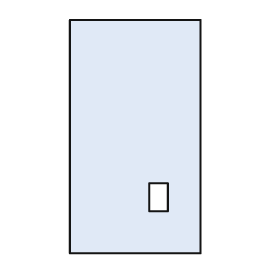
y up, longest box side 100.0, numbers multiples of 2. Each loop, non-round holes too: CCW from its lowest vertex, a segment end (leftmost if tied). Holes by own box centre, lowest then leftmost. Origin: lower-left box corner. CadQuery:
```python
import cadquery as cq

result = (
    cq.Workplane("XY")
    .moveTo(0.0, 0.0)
    .lineTo(56.0, 0.0)
    .lineTo(56.0, 100.0)
    .lineTo(0.0, 100.0)
    .close()
    .moveTo(34.0, 18.0)
    .lineTo(42.0, 18.0)
    .lineTo(42.0, 30.0)
    .lineTo(34.0, 30.0)
    .close()
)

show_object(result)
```